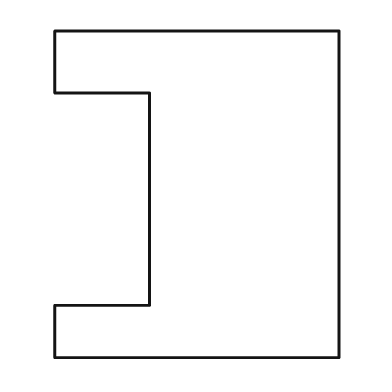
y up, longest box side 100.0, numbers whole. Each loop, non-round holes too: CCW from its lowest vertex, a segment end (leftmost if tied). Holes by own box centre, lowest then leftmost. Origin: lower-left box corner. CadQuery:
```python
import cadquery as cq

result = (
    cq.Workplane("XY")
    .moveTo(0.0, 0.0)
    .lineTo(87.0, 0.0)
    .lineTo(87.0, 100.0)
    .lineTo(0.0, 100.0)
    .lineTo(0.0, 81.0)
    .lineTo(29.0, 81.0)
    .lineTo(29.0, 16.0)
    .lineTo(0.0, 16.0)
    .close()
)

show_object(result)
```